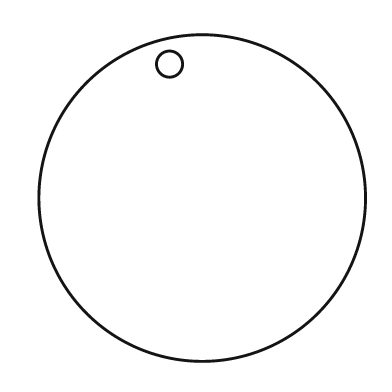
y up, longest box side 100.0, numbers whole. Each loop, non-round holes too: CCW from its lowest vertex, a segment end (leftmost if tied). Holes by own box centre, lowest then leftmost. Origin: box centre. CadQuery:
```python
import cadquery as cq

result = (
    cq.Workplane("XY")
    .moveTo(0.0, 0.0)
    .circle(50.0)
    .moveTo(-10.0, 41.0)
    .circle(4.0)
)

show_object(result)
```